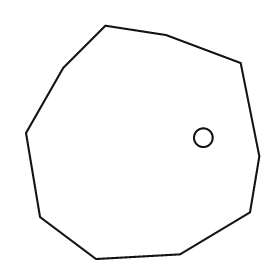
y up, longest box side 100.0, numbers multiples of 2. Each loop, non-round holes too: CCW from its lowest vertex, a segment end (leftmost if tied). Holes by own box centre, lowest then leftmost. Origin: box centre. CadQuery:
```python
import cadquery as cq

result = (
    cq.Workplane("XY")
    .moveTo(-20.0, -50.0)
    .lineTo(16.0, -48.0)
    .lineTo(46.0, -30.0)
    .lineTo(50.0, -6.0)
    .lineTo(42.0, 34.0)
    .lineTo(10.0, 46.0)
    .lineTo(-16.0, 50.0)
    .lineTo(-34.0, 32.0)
    .lineTo(-50.0, 4.0)
    .lineTo(-44.0, -32.0)
    .close()
    .moveTo(26.0, 2.0)
    .circle(4.0)
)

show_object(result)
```